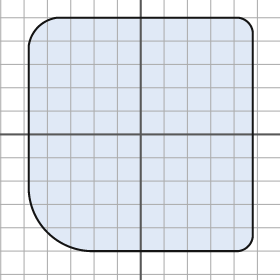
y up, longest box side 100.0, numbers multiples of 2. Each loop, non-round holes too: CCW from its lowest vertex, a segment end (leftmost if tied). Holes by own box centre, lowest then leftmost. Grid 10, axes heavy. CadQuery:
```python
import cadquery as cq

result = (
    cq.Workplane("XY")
    .moveTo(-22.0, -50.0)
    .lineTo(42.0, -50.0)
    .threePointArc((46.0, -48.0), (48.0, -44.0))
    .lineTo(48.0, 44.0)
    .threePointArc((46.0, 48.0), (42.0, 50.0))
    .lineTo(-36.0, 50.0)
    .threePointArc((-44.0, 46.0), (-48.0, 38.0))
    .lineTo(-48.0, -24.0)
    .threePointArc((-40.0, -42.0), (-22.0, -50.0))
    .close()
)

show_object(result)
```